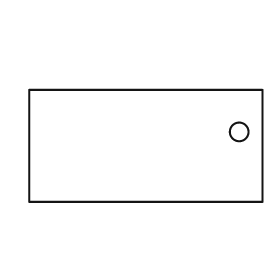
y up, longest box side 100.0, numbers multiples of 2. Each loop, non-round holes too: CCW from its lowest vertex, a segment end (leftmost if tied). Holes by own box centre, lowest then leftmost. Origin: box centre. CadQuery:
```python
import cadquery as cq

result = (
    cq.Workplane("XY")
    .moveTo(-50.0, -24.0)
    .lineTo(50.0, -24.0)
    .lineTo(50.0, 24.0)
    .lineTo(-50.0, 24.0)
    .close()
    .moveTo(40.0, 6.0)
    .circle(4.0)
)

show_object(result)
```